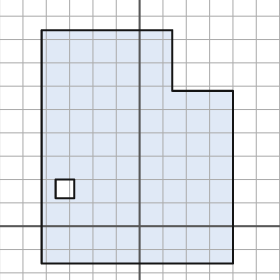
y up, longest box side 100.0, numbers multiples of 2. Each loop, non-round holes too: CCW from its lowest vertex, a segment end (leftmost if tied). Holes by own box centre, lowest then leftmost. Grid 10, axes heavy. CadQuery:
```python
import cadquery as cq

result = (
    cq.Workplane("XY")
    .moveTo(-42.0, -16.0)
    .lineTo(40.0, -16.0)
    .lineTo(40.0, 58.0)
    .lineTo(14.0, 58.0)
    .lineTo(14.0, 84.0)
    .lineTo(-42.0, 84.0)
    .close()
    .moveTo(-36.0, 12.0)
    .lineTo(-28.0, 12.0)
    .lineTo(-28.0, 20.0)
    .lineTo(-36.0, 20.0)
    .close()
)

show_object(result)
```